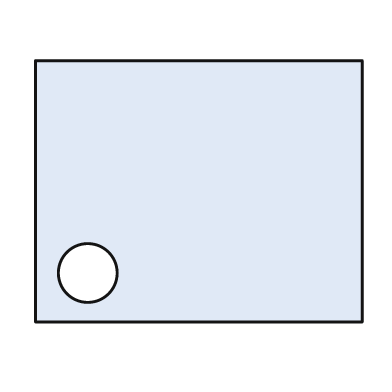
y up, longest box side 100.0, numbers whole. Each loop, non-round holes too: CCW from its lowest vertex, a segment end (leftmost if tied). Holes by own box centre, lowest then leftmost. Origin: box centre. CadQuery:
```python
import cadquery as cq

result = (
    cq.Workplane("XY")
    .moveTo(-50.0, -40.0)
    .lineTo(50.0, -40.0)
    .lineTo(50.0, 40.0)
    .lineTo(-50.0, 40.0)
    .close()
    .moveTo(-34.0, -25.0)
    .circle(9.0)
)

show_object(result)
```